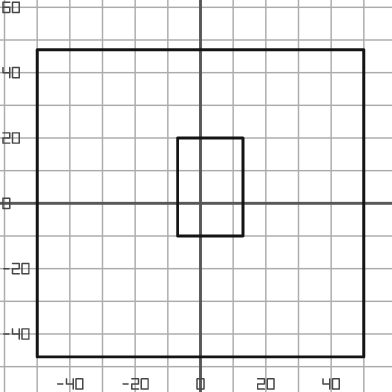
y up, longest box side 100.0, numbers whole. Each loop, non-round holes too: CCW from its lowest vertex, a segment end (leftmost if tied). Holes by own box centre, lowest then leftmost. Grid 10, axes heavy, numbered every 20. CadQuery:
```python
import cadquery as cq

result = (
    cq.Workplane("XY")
    .moveTo(-50.0, -47.0)
    .lineTo(50.0, -47.0)
    .lineTo(50.0, 47.0)
    .lineTo(-50.0, 47.0)
    .close()
    .moveTo(-7.0, -10.0)
    .lineTo(13.0, -10.0)
    .lineTo(13.0, 20.0)
    .lineTo(-7.0, 20.0)
    .close()
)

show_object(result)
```